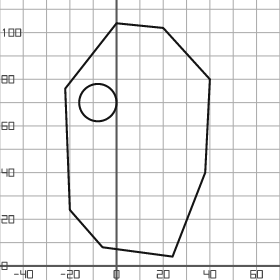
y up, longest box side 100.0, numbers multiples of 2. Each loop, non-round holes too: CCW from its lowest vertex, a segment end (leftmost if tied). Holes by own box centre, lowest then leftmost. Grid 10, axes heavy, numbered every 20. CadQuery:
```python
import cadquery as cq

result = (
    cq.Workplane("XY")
    .moveTo(24.0, 4.0)
    .lineTo(38.0, 40.0)
    .lineTo(40.0, 80.0)
    .lineTo(20.0, 102.0)
    .lineTo(0.0, 104.0)
    .lineTo(-22.0, 76.0)
    .lineTo(-20.0, 24.0)
    .lineTo(-6.0, 8.0)
    .close()
    .moveTo(-8.0, 70.0)
    .circle(8.0)
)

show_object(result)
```